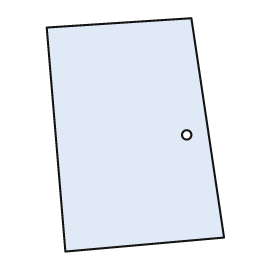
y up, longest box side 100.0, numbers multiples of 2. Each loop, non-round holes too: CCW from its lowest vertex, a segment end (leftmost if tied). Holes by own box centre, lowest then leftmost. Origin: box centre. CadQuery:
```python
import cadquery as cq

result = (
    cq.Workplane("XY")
    .moveTo(-30.0, -50.0)
    .lineTo(38.0, -44.0)
    .lineTo(24.0, 50.0)
    .lineTo(-38.0, 46.0)
    .close()
    .moveTo(22.0, 0.0)
    .circle(2.0)
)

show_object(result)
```